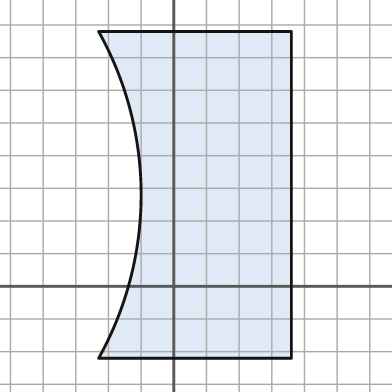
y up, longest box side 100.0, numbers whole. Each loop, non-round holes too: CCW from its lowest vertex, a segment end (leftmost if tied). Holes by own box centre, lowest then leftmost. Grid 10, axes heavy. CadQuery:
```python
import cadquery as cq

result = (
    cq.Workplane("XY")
    .moveTo(-23.0, -22.0)
    .lineTo(36.0, -22.0)
    .lineTo(36.0, 78.0)
    .lineTo(-23.0, 78.0)
    .threePointArc((-10.0, 28.0), (-23.0, -22.0))
    .close()
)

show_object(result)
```